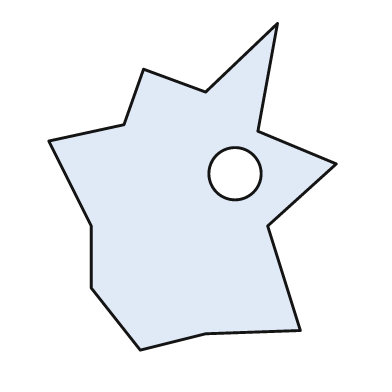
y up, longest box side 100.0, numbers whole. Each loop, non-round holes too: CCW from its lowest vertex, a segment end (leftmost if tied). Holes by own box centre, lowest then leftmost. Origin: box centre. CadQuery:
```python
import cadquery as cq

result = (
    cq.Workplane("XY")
    .moveTo(-16.0, -50.0)
    .lineTo(4.0, -45.0)
    .lineTo(33.0, -44.0)
    .lineTo(23.0, -12.0)
    .lineTo(44.0, 7.0)
    .lineTo(20.0, 17.0)
    .lineTo(26.0, 50.0)
    .lineTo(4.0, 29.0)
    .lineTo(-15.0, 36.0)
    .lineTo(-21.0, 19.0)
    .lineTo(-44.0, 14.0)
    .lineTo(-31.0, -12.0)
    .lineTo(-31.0, -31.0)
    .close()
    .moveTo(13.0, 4.0)
    .circle(8.0)
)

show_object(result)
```